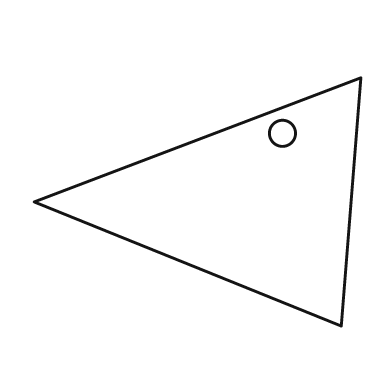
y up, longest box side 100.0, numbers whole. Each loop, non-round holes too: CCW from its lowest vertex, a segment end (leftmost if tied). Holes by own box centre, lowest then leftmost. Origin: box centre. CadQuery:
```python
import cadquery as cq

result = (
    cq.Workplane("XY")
    .moveTo(44.0, -38.0)
    .lineTo(50.0, 38.0)
    .lineTo(-50.0, 0.0)
    .close()
    .moveTo(26.0, 21.0)
    .circle(4.0)
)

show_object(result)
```